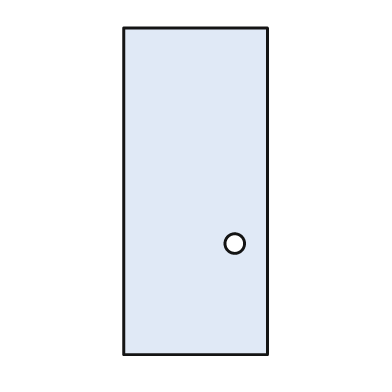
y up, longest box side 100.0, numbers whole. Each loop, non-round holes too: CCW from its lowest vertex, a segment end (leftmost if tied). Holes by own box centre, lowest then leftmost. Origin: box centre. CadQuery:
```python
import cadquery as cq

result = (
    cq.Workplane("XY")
    .moveTo(-22.0, -50.0)
    .lineTo(22.0, -50.0)
    .lineTo(22.0, 50.0)
    .lineTo(-22.0, 50.0)
    .close()
    .moveTo(12.0, -16.0)
    .circle(3.0)
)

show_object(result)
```